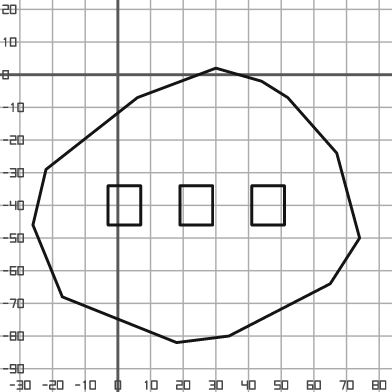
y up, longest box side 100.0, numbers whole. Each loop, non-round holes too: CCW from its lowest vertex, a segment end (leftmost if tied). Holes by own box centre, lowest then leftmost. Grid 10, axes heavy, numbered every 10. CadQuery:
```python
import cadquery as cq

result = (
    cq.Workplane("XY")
    .moveTo(18.0, -82.0)
    .lineTo(34.0, -80.0)
    .lineTo(65.0, -64.0)
    .lineTo(74.0, -50.0)
    .lineTo(67.0, -24.0)
    .lineTo(52.0, -7.0)
    .lineTo(44.0, -2.0)
    .lineTo(30.0, 2.0)
    .lineTo(6.0, -7.0)
    .lineTo(-22.0, -29.0)
    .lineTo(-26.0, -46.0)
    .lineTo(-17.0, -68.0)
    .close()
    .moveTo(-3.0, -46.0)
    .lineTo(7.0, -46.0)
    .lineTo(7.0, -34.0)
    .lineTo(-3.0, -34.0)
    .close()
    .moveTo(19.0, -46.0)
    .lineTo(29.0, -46.0)
    .lineTo(29.0, -34.0)
    .lineTo(19.0, -34.0)
    .close()
    .moveTo(41.0, -46.0)
    .lineTo(51.0, -46.0)
    .lineTo(51.0, -34.0)
    .lineTo(41.0, -34.0)
    .close()
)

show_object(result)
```